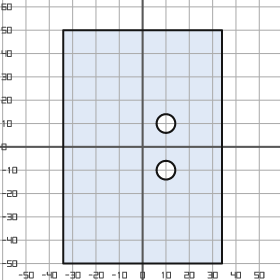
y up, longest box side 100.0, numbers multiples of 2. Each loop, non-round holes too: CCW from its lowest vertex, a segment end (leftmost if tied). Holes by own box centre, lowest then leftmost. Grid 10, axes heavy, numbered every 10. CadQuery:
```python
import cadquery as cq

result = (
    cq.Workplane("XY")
    .moveTo(-34.0, -50.0)
    .lineTo(34.0, -50.0)
    .lineTo(34.0, 50.0)
    .lineTo(-34.0, 50.0)
    .close()
    .moveTo(10.0, -10.0)
    .circle(4.0)
    .moveTo(10.0, 10.0)
    .circle(4.0)
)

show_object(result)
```